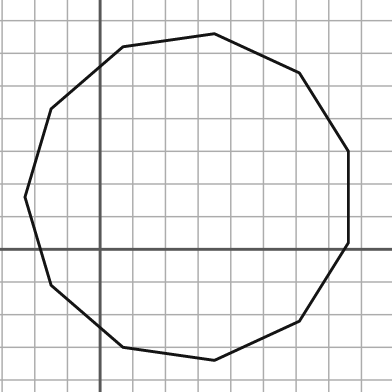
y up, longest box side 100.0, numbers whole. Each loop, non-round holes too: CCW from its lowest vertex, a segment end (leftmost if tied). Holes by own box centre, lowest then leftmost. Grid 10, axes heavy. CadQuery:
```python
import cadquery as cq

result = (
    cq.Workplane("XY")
    .moveTo(35.0, -34.0)
    .lineTo(61.0, -22.0)
    .lineTo(76.0, 2.0)
    .lineTo(76.0, 30.0)
    .lineTo(61.0, 54.0)
    .lineTo(35.0, 66.0)
    .lineTo(7.0, 62.0)
    .lineTo(-15.0, 43.0)
    .lineTo(-23.0, 16.0)
    .lineTo(-15.0, -11.0)
    .lineTo(7.0, -30.0)
    .close()
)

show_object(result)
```